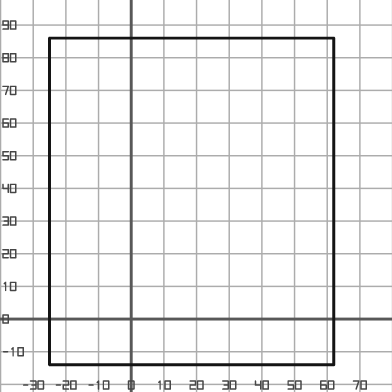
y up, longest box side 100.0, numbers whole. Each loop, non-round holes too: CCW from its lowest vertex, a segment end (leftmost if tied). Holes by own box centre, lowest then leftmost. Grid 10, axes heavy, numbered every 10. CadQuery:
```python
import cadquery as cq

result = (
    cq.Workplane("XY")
    .moveTo(-25.0, -14.0)
    .lineTo(62.0, -14.0)
    .lineTo(62.0, 86.0)
    .lineTo(-25.0, 86.0)
    .close()
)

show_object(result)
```